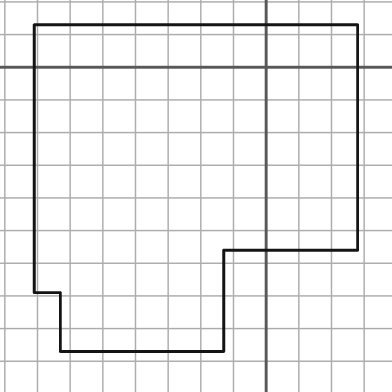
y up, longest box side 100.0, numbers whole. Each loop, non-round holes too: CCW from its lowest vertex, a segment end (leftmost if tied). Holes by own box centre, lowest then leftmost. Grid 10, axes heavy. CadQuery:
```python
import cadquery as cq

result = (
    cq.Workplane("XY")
    .moveTo(-63.0, -87.0)
    .lineTo(-13.0, -87.0)
    .lineTo(-13.0, -56.0)
    .lineTo(28.0, -56.0)
    .lineTo(28.0, 13.0)
    .lineTo(-71.0, 13.0)
    .lineTo(-71.0, -69.0)
    .lineTo(-63.0, -69.0)
    .close()
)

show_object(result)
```